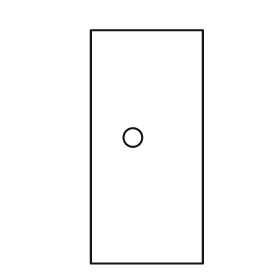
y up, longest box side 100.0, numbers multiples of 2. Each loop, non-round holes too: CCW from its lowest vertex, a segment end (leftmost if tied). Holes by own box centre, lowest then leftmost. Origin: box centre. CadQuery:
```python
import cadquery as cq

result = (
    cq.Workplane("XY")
    .moveTo(-24.0, -50.0)
    .lineTo(24.0, -50.0)
    .lineTo(24.0, 50.0)
    .lineTo(-24.0, 50.0)
    .close()
    .moveTo(-6.0, 4.0)
    .circle(4.0)
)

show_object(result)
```